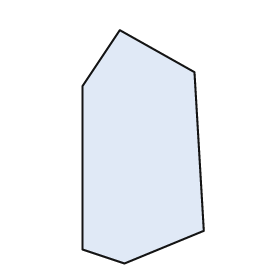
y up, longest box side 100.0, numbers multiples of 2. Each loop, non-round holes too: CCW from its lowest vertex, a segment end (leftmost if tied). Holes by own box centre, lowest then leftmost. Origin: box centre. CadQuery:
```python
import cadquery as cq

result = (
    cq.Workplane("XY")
    .moveTo(-8.0, -50.0)
    .lineTo(26.0, -36.0)
    .lineTo(22.0, 32.0)
    .lineTo(-10.0, 50.0)
    .lineTo(-26.0, 26.0)
    .lineTo(-26.0, -44.0)
    .close()
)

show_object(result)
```